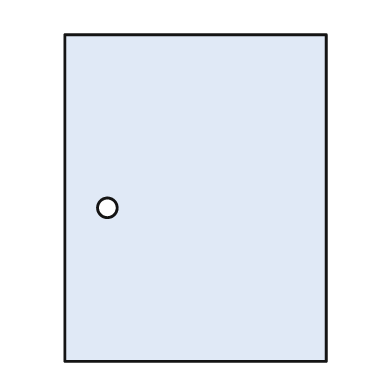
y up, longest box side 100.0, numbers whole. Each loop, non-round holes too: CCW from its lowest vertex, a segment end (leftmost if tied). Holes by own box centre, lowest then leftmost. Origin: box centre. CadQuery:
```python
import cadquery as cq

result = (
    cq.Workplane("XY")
    .moveTo(-40.0, -50.0)
    .lineTo(40.0, -50.0)
    .lineTo(40.0, 50.0)
    .lineTo(-40.0, 50.0)
    .close()
    .moveTo(-27.0, -3.0)
    .circle(3.0)
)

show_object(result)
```